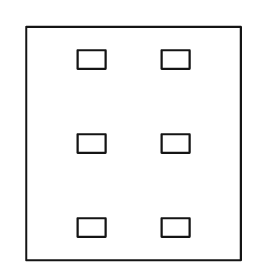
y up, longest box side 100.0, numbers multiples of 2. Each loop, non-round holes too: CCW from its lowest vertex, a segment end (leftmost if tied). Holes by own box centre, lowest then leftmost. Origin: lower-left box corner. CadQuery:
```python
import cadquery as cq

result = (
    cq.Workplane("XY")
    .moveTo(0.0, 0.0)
    .lineTo(92.0, 0.0)
    .lineTo(92.0, 100.0)
    .lineTo(0.0, 100.0)
    .close()
    .moveTo(22.0, 10.0)
    .lineTo(34.0, 10.0)
    .lineTo(34.0, 18.0)
    .lineTo(22.0, 18.0)
    .close()
    .moveTo(58.0, 10.0)
    .lineTo(70.0, 10.0)
    .lineTo(70.0, 18.0)
    .lineTo(58.0, 18.0)
    .close()
    .moveTo(22.0, 46.0)
    .lineTo(34.0, 46.0)
    .lineTo(34.0, 54.0)
    .lineTo(22.0, 54.0)
    .close()
    .moveTo(58.0, 46.0)
    .lineTo(70.0, 46.0)
    .lineTo(70.0, 54.0)
    .lineTo(58.0, 54.0)
    .close()
    .moveTo(22.0, 82.0)
    .lineTo(34.0, 82.0)
    .lineTo(34.0, 90.0)
    .lineTo(22.0, 90.0)
    .close()
    .moveTo(58.0, 82.0)
    .lineTo(70.0, 82.0)
    .lineTo(70.0, 90.0)
    .lineTo(58.0, 90.0)
    .close()
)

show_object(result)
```